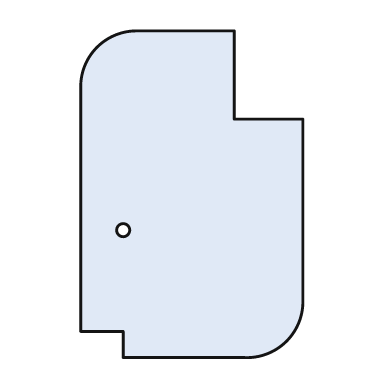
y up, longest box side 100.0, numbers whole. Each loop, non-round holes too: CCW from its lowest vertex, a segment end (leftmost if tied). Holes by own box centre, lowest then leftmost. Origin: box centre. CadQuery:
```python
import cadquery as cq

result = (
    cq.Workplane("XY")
    .moveTo(-21.0, -50.0)
    .lineTo(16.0, -50.0)
    .threePointArc((29.0, -45.0), (34.0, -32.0))
    .lineTo(34.0, 23.0)
    .lineTo(13.0, 23.0)
    .lineTo(13.0, 50.0)
    .lineTo(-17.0, 50.0)
    .threePointArc((-29.0, 45.0), (-34.0, 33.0))
    .lineTo(-34.0, -42.0)
    .lineTo(-21.0, -42.0)
    .close()
    .moveTo(-21.0, -11.0)
    .circle(2.0)
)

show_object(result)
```